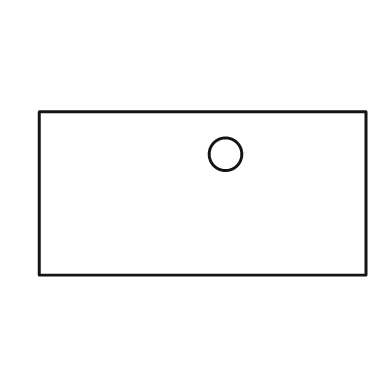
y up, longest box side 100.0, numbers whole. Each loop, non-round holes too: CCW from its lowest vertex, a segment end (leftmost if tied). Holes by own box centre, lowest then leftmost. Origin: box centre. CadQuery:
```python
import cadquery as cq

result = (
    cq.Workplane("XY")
    .moveTo(-50.0, -25.0)
    .lineTo(50.0, -25.0)
    .lineTo(50.0, 25.0)
    .lineTo(-50.0, 25.0)
    .close()
    .moveTo(7.0, 12.0)
    .circle(5.0)
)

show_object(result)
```